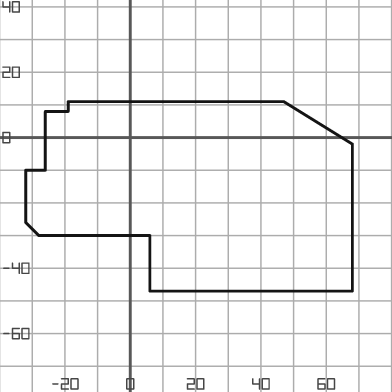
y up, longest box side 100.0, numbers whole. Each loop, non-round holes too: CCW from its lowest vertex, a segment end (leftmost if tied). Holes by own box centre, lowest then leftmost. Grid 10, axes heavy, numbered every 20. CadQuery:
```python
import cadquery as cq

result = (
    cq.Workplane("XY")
    .moveTo(6.0, -47.0)
    .lineTo(68.0, -47.0)
    .lineTo(68.0, -2.0)
    .lineTo(47.0, 11.0)
    .lineTo(-19.0, 11.0)
    .lineTo(-19.0, 8.0)
    .lineTo(-26.0, 8.0)
    .lineTo(-26.0, -10.0)
    .lineTo(-32.0, -10.0)
    .lineTo(-32.0, -26.0)
    .lineTo(-28.0, -30.0)
    .lineTo(6.0, -30.0)
    .close()
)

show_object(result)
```